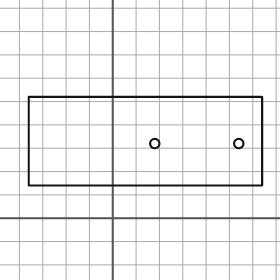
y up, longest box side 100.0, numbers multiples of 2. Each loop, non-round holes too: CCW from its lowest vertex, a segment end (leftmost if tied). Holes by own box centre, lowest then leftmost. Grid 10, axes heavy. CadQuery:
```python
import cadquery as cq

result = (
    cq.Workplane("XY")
    .moveTo(-36.0, 14.0)
    .lineTo(64.0, 14.0)
    .lineTo(64.0, 52.0)
    .lineTo(-36.0, 52.0)
    .close()
    .moveTo(18.0, 32.0)
    .circle(2.0)
    .moveTo(54.0, 32.0)
    .circle(2.0)
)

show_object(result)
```